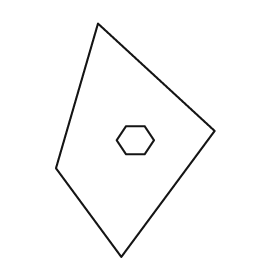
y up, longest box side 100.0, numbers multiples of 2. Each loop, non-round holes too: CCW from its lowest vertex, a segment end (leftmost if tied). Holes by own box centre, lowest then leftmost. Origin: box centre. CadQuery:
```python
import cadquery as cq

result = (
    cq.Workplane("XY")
    .moveTo(-6.0, -50.0)
    .lineTo(34.0, 4.0)
    .lineTo(-16.0, 50.0)
    .lineTo(-34.0, -12.0)
    .close()
    .moveTo(-4.0, -6.0)
    .lineTo(4.0, -6.0)
    .lineTo(8.0, 0.0)
    .lineTo(4.0, 6.0)
    .lineTo(-4.0, 6.0)
    .lineTo(-8.0, 0.0)
    .close()
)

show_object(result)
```